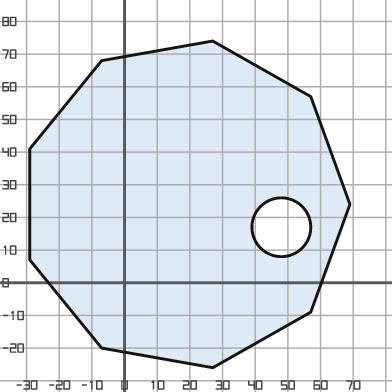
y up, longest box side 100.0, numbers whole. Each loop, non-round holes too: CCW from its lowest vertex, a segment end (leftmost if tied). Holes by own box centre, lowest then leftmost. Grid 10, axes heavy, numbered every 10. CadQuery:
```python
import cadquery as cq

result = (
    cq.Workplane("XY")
    .moveTo(27.0, -26.0)
    .lineTo(57.0, -9.0)
    .lineTo(69.0, 24.0)
    .lineTo(57.0, 57.0)
    .lineTo(27.0, 74.0)
    .lineTo(-7.0, 68.0)
    .lineTo(-29.0, 41.0)
    .lineTo(-29.0, 7.0)
    .lineTo(-7.0, -20.0)
    .close()
    .moveTo(48.0, 17.0)
    .circle(9.0)
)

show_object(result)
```